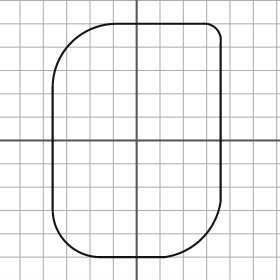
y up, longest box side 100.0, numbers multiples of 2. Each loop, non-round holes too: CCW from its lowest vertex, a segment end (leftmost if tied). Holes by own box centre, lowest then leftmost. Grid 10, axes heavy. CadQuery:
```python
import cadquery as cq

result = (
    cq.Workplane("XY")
    .moveTo(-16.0, -50.0)
    .lineTo(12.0, -50.0)
    .threePointArc((28.0, -42.0), (36.0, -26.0))
    .lineTo(36.0, 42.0)
    .threePointArc((34.0, 48.0), (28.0, 50.0))
    .lineTo(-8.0, 50.0)
    .threePointArc((-28.0, 42.0), (-36.0, 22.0))
    .lineTo(-36.0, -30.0)
    .threePointArc((-30.0, -44.0), (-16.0, -50.0))
    .close()
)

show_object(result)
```